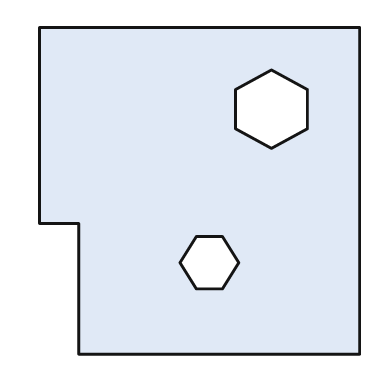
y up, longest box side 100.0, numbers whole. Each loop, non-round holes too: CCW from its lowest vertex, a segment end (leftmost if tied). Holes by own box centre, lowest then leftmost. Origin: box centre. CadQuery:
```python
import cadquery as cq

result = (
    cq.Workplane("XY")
    .moveTo(-37.0, -50.0)
    .lineTo(49.0, -50.0)
    .lineTo(49.0, 50.0)
    .lineTo(-49.0, 50.0)
    .lineTo(-49.0, -10.0)
    .lineTo(-37.0, -10.0)
    .close()
    .moveTo(-1.0, -30.0)
    .lineTo(7.0, -30.0)
    .lineTo(12.0, -22.0)
    .lineTo(7.0, -14.0)
    .lineTo(-1.0, -14.0)
    .lineTo(-6.0, -22.0)
    .close()
    .moveTo(22.0, 13.0)
    .lineTo(33.0, 19.0)
    .lineTo(33.0, 31.0)
    .lineTo(22.0, 37.0)
    .lineTo(11.0, 31.0)
    .lineTo(11.0, 19.0)
    .close()
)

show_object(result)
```